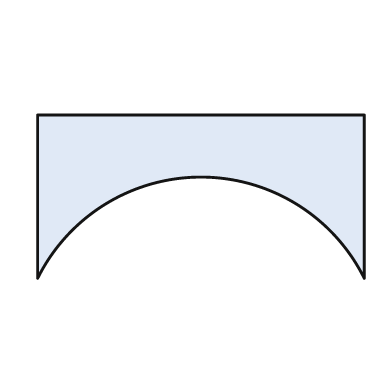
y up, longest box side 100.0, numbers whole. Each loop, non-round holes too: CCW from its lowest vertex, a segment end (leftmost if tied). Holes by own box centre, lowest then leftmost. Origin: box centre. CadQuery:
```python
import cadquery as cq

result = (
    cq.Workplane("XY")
    .moveTo(-50.0, -25.0)
    .threePointArc((0.0, 6.0), (50.0, -25.0))
    .lineTo(50.0, 25.0)
    .lineTo(-50.0, 25.0)
    .close()
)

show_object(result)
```